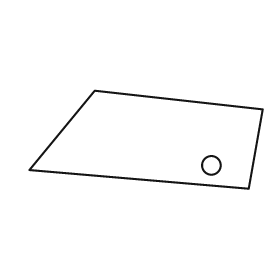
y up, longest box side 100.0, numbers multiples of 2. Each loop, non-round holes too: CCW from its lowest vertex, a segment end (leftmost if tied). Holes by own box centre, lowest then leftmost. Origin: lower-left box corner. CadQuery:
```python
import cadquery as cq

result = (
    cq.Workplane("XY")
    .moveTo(94.0, 0.0)
    .lineTo(100.0, 34.0)
    .lineTo(28.0, 42.0)
    .lineTo(0.0, 8.0)
    .close()
    .moveTo(78.0, 10.0)
    .circle(4.0)
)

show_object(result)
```